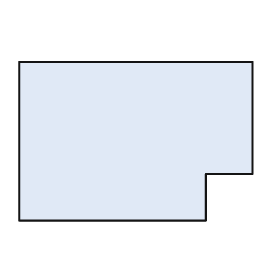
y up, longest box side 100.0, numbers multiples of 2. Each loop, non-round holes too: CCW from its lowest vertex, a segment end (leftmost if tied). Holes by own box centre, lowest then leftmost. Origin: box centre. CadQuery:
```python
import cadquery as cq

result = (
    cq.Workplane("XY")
    .moveTo(-50.0, -34.0)
    .lineTo(30.0, -34.0)
    .lineTo(30.0, -14.0)
    .lineTo(50.0, -14.0)
    .lineTo(50.0, 34.0)
    .lineTo(-50.0, 34.0)
    .close()
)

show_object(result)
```